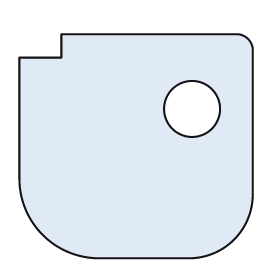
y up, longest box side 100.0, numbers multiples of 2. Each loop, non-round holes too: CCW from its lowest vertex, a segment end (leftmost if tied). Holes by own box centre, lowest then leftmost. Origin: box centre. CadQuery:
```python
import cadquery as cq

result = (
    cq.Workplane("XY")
    .moveTo(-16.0, -48.0)
    .lineTo(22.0, -48.0)
    .threePointArc((42.0, -40.0), (50.0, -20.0))
    .lineTo(50.0, 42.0)
    .threePointArc((48.0, 46.0), (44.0, 48.0))
    .lineTo(-32.0, 48.0)
    .lineTo(-32.0, 38.0)
    .lineTo(-50.0, 38.0)
    .lineTo(-50.0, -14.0)
    .threePointArc((-40.0, -38.0), (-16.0, -48.0))
    .close()
    .moveTo(24.0, 16.0)
    .circle(12.0)
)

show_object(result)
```